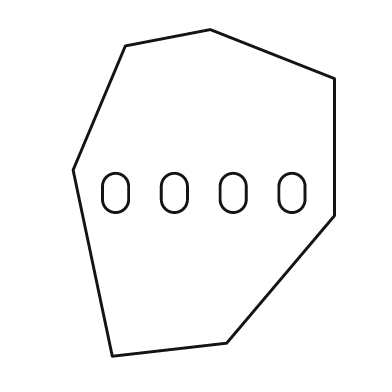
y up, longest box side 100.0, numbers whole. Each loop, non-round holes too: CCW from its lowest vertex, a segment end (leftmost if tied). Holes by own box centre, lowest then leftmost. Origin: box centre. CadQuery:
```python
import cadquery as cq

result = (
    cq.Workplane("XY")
    .moveTo(-28.0, -50.0)
    .lineTo(7.0, -46.0)
    .lineTo(40.0, -7.0)
    .lineTo(40.0, 35.0)
    .lineTo(2.0, 50.0)
    .lineTo(-24.0, 45.0)
    .lineTo(-40.0, 7.0)
    .close()
    .moveTo(-31.0, -2.0)
    .threePointArc((-27.0, -6.0), (-23.0, -2.0))
    .lineTo(-23.0, 2.0)
    .threePointArc((-27.0, 6.0), (-31.0, 2.0))
    .close()
    .moveTo(-13.0, -2.0)
    .threePointArc((-9.0, -6.0), (-5.0, -2.0))
    .lineTo(-5.0, 2.0)
    .threePointArc((-9.0, 6.0), (-13.0, 2.0))
    .close()
    .moveTo(5.0, -2.0)
    .threePointArc((9.0, -6.0), (13.0, -2.0))
    .lineTo(13.0, 2.0)
    .threePointArc((9.0, 6.0), (5.0, 2.0))
    .close()
    .moveTo(23.0, -2.0)
    .threePointArc((27.0, -6.0), (31.0, -2.0))
    .lineTo(31.0, 2.0)
    .threePointArc((27.0, 6.0), (23.0, 2.0))
    .close()
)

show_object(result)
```